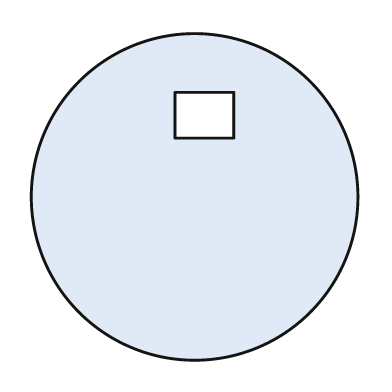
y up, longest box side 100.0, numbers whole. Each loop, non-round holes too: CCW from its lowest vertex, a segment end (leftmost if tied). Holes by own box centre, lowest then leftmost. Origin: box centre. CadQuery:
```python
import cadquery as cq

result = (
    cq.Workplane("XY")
    .moveTo(0.0, 0.0)
    .circle(50.0)
    .moveTo(-6.0, 18.0)
    .lineTo(12.0, 18.0)
    .lineTo(12.0, 32.0)
    .lineTo(-6.0, 32.0)
    .close()
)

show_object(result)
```